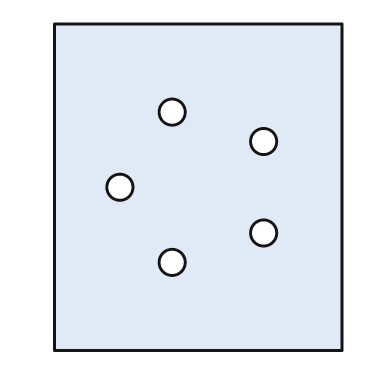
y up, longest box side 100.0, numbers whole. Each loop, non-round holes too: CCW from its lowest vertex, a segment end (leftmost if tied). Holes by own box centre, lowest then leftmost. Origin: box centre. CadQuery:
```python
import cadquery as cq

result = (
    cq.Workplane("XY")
    .moveTo(-44.0, -50.0)
    .lineTo(44.0, -50.0)
    .lineTo(44.0, 50.0)
    .lineTo(-44.0, 50.0)
    .close()
    .moveTo(-8.0, -23.0)
    .circle(4.0)
    .moveTo(20.0, -14.0)
    .circle(4.0)
    .moveTo(-24.0, 0.0)
    .circle(4.0)
    .moveTo(20.0, 14.0)
    .circle(4.0)
    .moveTo(-8.0, 23.0)
    .circle(4.0)
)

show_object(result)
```